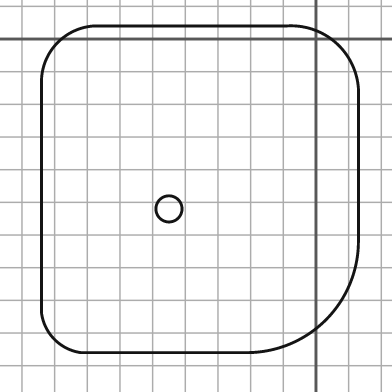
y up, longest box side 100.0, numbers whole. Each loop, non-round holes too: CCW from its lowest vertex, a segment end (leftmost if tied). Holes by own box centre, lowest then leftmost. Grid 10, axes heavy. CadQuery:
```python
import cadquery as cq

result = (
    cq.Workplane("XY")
    .moveTo(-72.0, -96.0)
    .lineTo(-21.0, -96.0)
    .threePointArc((3.0, -86.0), (13.0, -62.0))
    .lineTo(13.0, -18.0)
    .threePointArc((7.0, -2.0), (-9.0, 4.0))
    .lineTo(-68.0, 4.0)
    .threePointArc((-79.0, -1.0), (-84.0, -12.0))
    .lineTo(-84.0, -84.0)
    .threePointArc((-80.0, -92.0), (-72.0, -96.0))
    .close()
    .moveTo(-45.0, -52.0)
    .circle(4.0)
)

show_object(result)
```